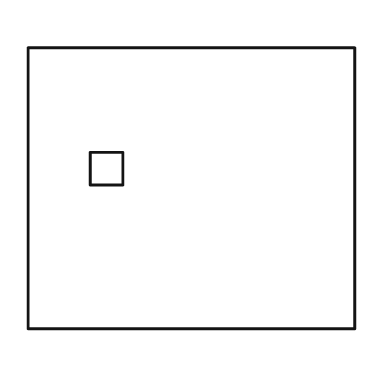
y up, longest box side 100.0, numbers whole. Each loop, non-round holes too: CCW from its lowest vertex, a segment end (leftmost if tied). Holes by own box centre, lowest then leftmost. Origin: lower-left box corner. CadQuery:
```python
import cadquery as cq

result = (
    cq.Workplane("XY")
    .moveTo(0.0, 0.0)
    .lineTo(100.0, 0.0)
    .lineTo(100.0, 86.0)
    .lineTo(0.0, 86.0)
    .close()
    .moveTo(19.0, 44.0)
    .lineTo(29.0, 44.0)
    .lineTo(29.0, 54.0)
    .lineTo(19.0, 54.0)
    .close()
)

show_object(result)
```